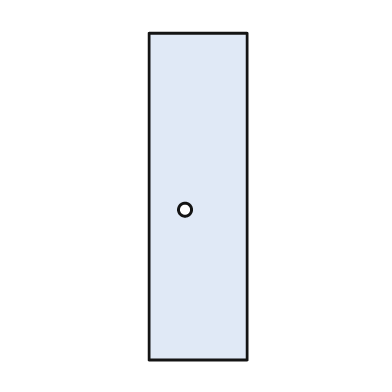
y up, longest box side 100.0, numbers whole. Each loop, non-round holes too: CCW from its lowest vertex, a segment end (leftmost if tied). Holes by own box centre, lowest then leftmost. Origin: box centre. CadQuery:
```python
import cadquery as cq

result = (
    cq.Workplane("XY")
    .moveTo(-15.0, -50.0)
    .lineTo(15.0, -50.0)
    .lineTo(15.0, 50.0)
    .lineTo(-15.0, 50.0)
    .close()
    .moveTo(-4.0, -4.0)
    .circle(2.0)
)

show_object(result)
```